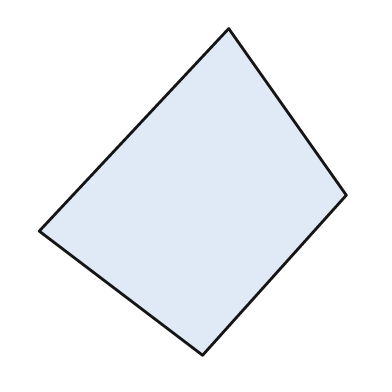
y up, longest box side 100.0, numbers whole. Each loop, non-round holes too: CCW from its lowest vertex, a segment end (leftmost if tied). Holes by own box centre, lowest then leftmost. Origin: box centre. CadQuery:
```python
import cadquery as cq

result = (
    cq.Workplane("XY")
    .moveTo(3.0, -50.0)
    .lineTo(47.0, -1.0)
    .lineTo(11.0, 50.0)
    .lineTo(-47.0, -12.0)
    .close()
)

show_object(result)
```